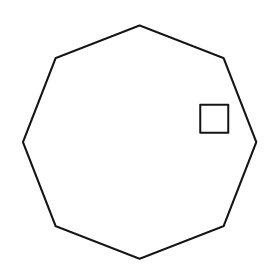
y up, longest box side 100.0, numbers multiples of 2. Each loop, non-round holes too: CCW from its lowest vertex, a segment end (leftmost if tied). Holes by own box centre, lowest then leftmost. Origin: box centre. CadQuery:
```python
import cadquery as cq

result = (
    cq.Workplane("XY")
    .moveTo(0.0, -50.0)
    .lineTo(36.0, -36.0)
    .lineTo(50.0, 0.0)
    .lineTo(36.0, 36.0)
    .lineTo(0.0, 50.0)
    .lineTo(-36.0, 36.0)
    .lineTo(-50.0, 0.0)
    .lineTo(-36.0, -36.0)
    .close()
    .moveTo(26.0, 4.0)
    .lineTo(38.0, 4.0)
    .lineTo(38.0, 16.0)
    .lineTo(26.0, 16.0)
    .close()
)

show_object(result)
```